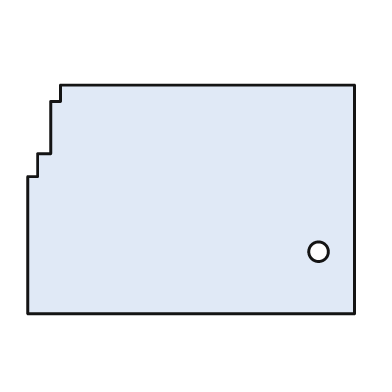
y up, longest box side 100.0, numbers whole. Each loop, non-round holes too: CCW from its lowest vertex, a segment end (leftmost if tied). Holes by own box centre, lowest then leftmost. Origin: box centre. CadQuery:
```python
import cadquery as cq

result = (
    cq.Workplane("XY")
    .moveTo(-50.0, -35.0)
    .lineTo(50.0, -35.0)
    .lineTo(50.0, 35.0)
    .lineTo(-40.0, 35.0)
    .lineTo(-40.0, 30.0)
    .lineTo(-43.0, 30.0)
    .lineTo(-43.0, 14.0)
    .lineTo(-47.0, 14.0)
    .lineTo(-47.0, 7.0)
    .lineTo(-50.0, 7.0)
    .close()
    .moveTo(39.0, -16.0)
    .circle(3.0)
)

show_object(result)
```